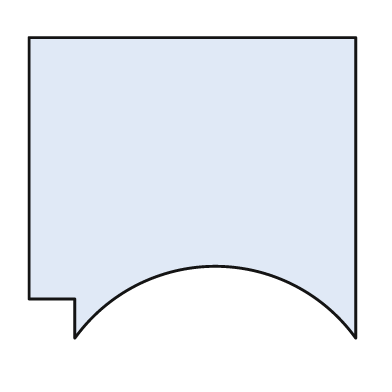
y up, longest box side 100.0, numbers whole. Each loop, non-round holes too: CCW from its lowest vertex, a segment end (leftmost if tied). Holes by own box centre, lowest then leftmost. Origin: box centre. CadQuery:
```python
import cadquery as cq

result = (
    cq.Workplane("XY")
    .moveTo(-36.0, -46.0)
    .threePointArc((7.0, -24.0), (50.0, -46.0))
    .lineTo(50.0, 46.0)
    .lineTo(-50.0, 46.0)
    .lineTo(-50.0, -34.0)
    .lineTo(-36.0, -34.0)
    .close()
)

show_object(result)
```